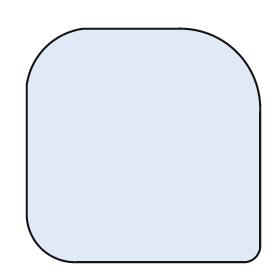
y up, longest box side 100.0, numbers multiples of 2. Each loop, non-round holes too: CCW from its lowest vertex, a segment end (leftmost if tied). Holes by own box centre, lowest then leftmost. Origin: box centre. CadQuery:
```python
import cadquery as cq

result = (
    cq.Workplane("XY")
    .moveTo(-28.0, -50.0)
    .lineTo(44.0, -50.0)
    .threePointArc((48.0, -48.0), (50.0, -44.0))
    .lineTo(50.0, 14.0)
    .threePointArc((40.0, 40.0), (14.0, 50.0))
    .lineTo(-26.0, 50.0)
    .threePointArc((-42.0, 42.0), (-50.0, 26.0))
    .lineTo(-50.0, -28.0)
    .threePointArc((-44.0, -44.0), (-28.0, -50.0))
    .close()
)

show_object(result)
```